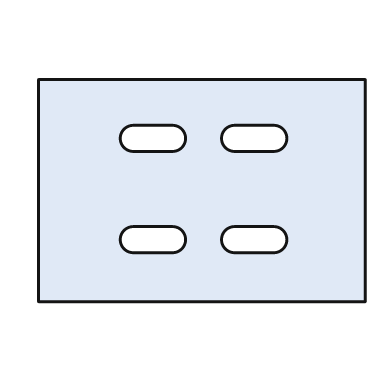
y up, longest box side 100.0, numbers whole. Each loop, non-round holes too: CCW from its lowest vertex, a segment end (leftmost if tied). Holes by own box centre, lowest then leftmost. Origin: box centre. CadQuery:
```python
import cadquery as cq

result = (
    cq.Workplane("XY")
    .moveTo(-50.0, -34.0)
    .lineTo(50.0, -34.0)
    .lineTo(50.0, 34.0)
    .lineTo(-50.0, 34.0)
    .close()
    .moveTo(-21.0, -19.0)
    .lineTo(-9.0, -19.0)
    .threePointArc((-5.0, -15.0), (-9.0, -11.0))
    .lineTo(-21.0, -11.0)
    .threePointArc((-25.0, -15.0), (-21.0, -19.0))
    .close()
    .moveTo(10.0, -19.0)
    .lineTo(22.0, -19.0)
    .threePointArc((26.0, -15.0), (22.0, -11.0))
    .lineTo(10.0, -11.0)
    .threePointArc((6.0, -15.0), (10.0, -19.0))
    .close()
    .moveTo(-21.0, 12.0)
    .lineTo(-9.0, 12.0)
    .threePointArc((-5.0, 16.0), (-9.0, 20.0))
    .lineTo(-21.0, 20.0)
    .threePointArc((-25.0, 16.0), (-21.0, 12.0))
    .close()
    .moveTo(10.0, 12.0)
    .lineTo(22.0, 12.0)
    .threePointArc((26.0, 16.0), (22.0, 20.0))
    .lineTo(10.0, 20.0)
    .threePointArc((6.0, 16.0), (10.0, 12.0))
    .close()
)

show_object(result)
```